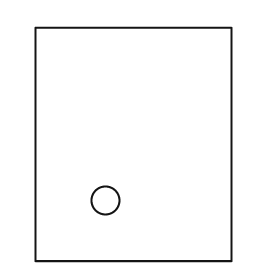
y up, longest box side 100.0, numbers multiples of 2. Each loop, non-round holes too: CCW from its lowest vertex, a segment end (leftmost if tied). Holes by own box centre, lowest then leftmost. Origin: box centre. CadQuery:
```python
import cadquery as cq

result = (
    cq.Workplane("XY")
    .moveTo(-42.0, -50.0)
    .lineTo(42.0, -50.0)
    .lineTo(42.0, 50.0)
    .lineTo(-42.0, 50.0)
    .close()
    .moveTo(-12.0, -24.0)
    .circle(6.0)
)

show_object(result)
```